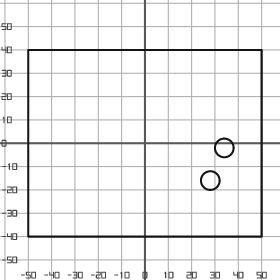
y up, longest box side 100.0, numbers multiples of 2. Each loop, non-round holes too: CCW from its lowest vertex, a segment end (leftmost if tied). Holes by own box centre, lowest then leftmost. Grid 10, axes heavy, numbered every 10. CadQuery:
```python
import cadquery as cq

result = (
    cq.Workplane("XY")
    .moveTo(-50.0, -40.0)
    .lineTo(50.0, -40.0)
    .lineTo(50.0, 40.0)
    .lineTo(-50.0, 40.0)
    .close()
    .moveTo(28.0, -16.0)
    .circle(4.0)
    .moveTo(34.0, -2.0)
    .circle(4.0)
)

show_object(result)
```